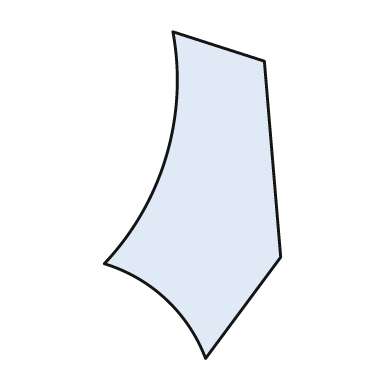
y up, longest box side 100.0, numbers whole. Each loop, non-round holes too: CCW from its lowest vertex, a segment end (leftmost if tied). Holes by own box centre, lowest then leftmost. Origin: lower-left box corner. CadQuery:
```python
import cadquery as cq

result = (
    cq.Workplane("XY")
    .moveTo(31.0, 0.0)
    .lineTo(54.0, 31.0)
    .lineTo(49.0, 91.0)
    .lineTo(21.0, 100.0)
    .threePointArc((19.0, 62.0), (0.0, 29.0))
    .threePointArc((19.0, 18.0), (31.0, 0.0))
    .close()
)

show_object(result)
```